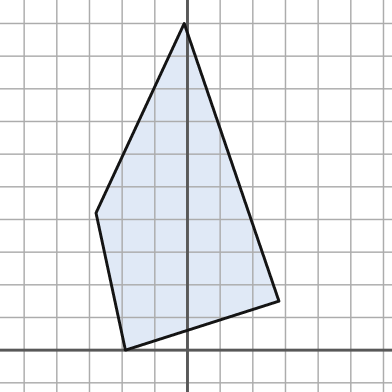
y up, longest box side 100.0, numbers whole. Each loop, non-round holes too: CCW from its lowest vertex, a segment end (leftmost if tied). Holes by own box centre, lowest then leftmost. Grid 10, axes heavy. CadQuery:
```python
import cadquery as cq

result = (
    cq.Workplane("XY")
    .moveTo(-19.0, 0.0)
    .lineTo(28.0, 15.0)
    .lineTo(-1.0, 100.0)
    .lineTo(-28.0, 42.0)
    .close()
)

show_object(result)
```